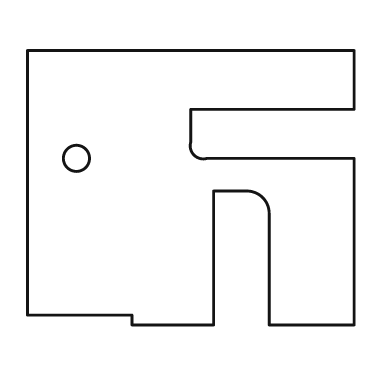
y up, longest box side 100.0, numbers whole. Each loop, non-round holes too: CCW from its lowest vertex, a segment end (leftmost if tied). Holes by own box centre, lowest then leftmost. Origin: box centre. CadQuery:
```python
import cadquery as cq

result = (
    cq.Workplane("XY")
    .moveTo(-18.0, -42.0)
    .lineTo(7.0, -42.0)
    .lineTo(7.0, -1.0)
    .lineTo(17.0, -1.0)
    .threePointArc((22.0, -3.0), (24.0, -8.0))
    .lineTo(24.0, -42.0)
    .lineTo(50.0, -42.0)
    .lineTo(50.0, 9.0)
    .lineTo(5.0, 9.0)
    .threePointArc((1.0, 10.0), (0.0, 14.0))
    .lineTo(0.0, 24.0)
    .lineTo(50.0, 24.0)
    .lineTo(50.0, 42.0)
    .lineTo(-50.0, 42.0)
    .lineTo(-50.0, -39.0)
    .lineTo(-18.0, -39.0)
    .close()
    .moveTo(-35.0, 9.0)
    .circle(4.0)
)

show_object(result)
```